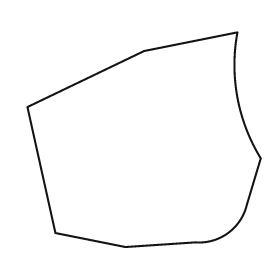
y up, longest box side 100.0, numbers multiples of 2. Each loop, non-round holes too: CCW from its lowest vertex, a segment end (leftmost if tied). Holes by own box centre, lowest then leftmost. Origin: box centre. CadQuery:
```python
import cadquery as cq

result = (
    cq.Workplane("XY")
    .moveTo(-8.0, -46.0)
    .lineTo(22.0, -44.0)
    .threePointArc((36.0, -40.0), (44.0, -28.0))
    .lineTo(50.0, -8.0)
    .threePointArc((40.0, 18.0), (40.0, 46.0))
    .lineTo(0.0, 38.0)
    .lineTo(-50.0, 14.0)
    .lineTo(-38.0, -40.0)
    .close()
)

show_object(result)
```